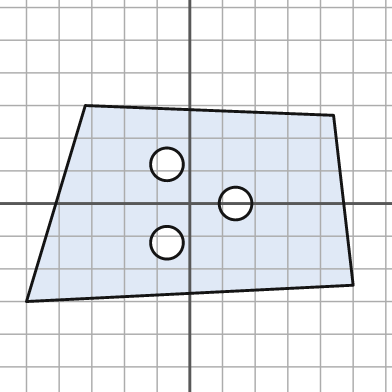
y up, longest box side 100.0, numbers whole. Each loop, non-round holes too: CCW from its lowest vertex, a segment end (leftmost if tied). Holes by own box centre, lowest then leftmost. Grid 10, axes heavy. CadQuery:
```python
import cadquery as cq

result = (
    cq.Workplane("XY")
    .moveTo(-50.0, -30.0)
    .lineTo(50.0, -25.0)
    .lineTo(44.0, 27.0)
    .lineTo(-32.0, 30.0)
    .close()
    .moveTo(-7.0, -12.0)
    .circle(5.0)
    .moveTo(14.0, 0.0)
    .circle(5.0)
    .moveTo(-7.0, 12.0)
    .circle(5.0)
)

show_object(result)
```